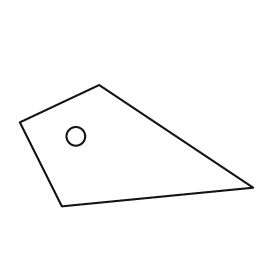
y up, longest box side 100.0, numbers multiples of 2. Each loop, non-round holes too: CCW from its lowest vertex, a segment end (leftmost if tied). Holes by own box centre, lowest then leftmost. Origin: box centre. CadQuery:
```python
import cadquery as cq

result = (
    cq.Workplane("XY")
    .moveTo(-32.0, -26.0)
    .lineTo(50.0, -18.0)
    .lineTo(-16.0, 26.0)
    .lineTo(-50.0, 10.0)
    .close()
    .moveTo(-26.0, 4.0)
    .circle(4.0)
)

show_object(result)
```